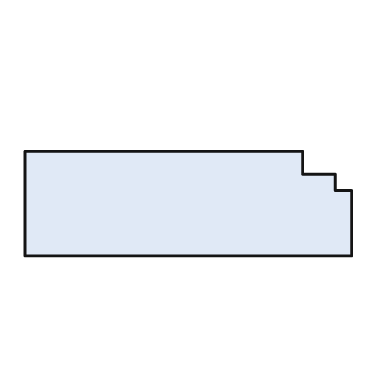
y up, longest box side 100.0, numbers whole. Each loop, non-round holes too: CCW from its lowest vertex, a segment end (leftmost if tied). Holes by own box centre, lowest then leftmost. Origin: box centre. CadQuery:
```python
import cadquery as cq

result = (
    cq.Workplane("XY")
    .moveTo(-50.0, -16.0)
    .lineTo(50.0, -16.0)
    .lineTo(50.0, 4.0)
    .lineTo(45.0, 4.0)
    .lineTo(45.0, 9.0)
    .lineTo(35.0, 9.0)
    .lineTo(35.0, 16.0)
    .lineTo(-50.0, 16.0)
    .close()
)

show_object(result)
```